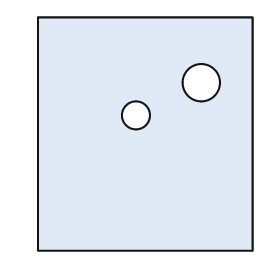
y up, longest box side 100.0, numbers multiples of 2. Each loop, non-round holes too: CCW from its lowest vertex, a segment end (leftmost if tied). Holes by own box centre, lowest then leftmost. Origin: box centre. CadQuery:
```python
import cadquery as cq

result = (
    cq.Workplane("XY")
    .moveTo(-46.0, -50.0)
    .lineTo(46.0, -50.0)
    .lineTo(46.0, 50.0)
    .lineTo(-46.0, 50.0)
    .close()
    .moveTo(-4.0, 8.0)
    .circle(6.0)
    .moveTo(24.0, 22.0)
    .circle(8.0)
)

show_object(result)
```